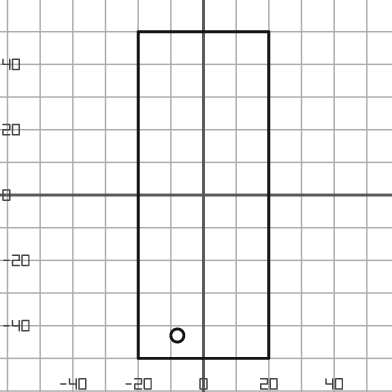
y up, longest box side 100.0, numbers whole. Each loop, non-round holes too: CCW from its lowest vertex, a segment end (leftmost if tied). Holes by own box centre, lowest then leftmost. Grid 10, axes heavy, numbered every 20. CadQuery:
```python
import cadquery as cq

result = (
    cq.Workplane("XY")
    .moveTo(-20.0, -50.0)
    .lineTo(20.0, -50.0)
    .lineTo(20.0, 50.0)
    .lineTo(-20.0, 50.0)
    .close()
    .moveTo(-8.0, -43.0)
    .circle(2.0)
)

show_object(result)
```